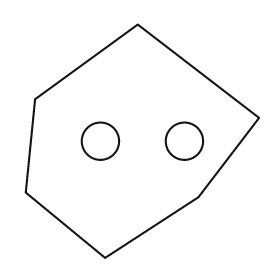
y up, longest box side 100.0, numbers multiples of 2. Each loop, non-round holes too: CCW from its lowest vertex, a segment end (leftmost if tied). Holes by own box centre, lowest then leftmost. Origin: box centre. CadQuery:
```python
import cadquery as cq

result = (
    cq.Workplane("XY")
    .moveTo(-16.0, -50.0)
    .lineTo(24.0, -24.0)
    .lineTo(50.0, 10.0)
    .lineTo(-2.0, 50.0)
    .lineTo(-46.0, 18.0)
    .lineTo(-50.0, -22.0)
    .close()
    .moveTo(-18.0, 0.0)
    .circle(8.0)
    .moveTo(18.0, 0.0)
    .circle(8.0)
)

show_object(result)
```